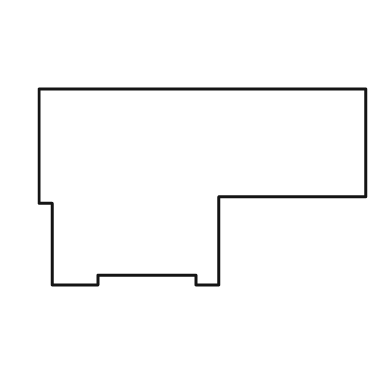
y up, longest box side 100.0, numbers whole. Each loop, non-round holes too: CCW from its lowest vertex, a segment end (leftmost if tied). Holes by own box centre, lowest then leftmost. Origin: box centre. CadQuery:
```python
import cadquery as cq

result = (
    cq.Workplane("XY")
    .moveTo(-46.0, -30.0)
    .lineTo(-32.0, -30.0)
    .lineTo(-32.0, -27.0)
    .lineTo(-2.0, -27.0)
    .lineTo(-2.0, -30.0)
    .lineTo(5.0, -30.0)
    .lineTo(5.0, -3.0)
    .lineTo(50.0, -3.0)
    .lineTo(50.0, 30.0)
    .lineTo(-50.0, 30.0)
    .lineTo(-50.0, -5.0)
    .lineTo(-46.0, -5.0)
    .close()
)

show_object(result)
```